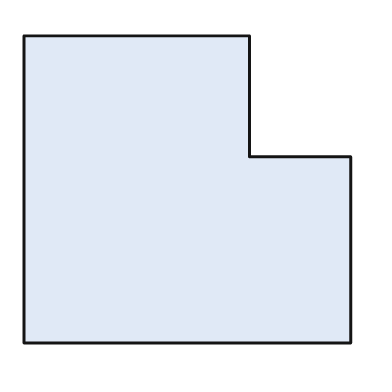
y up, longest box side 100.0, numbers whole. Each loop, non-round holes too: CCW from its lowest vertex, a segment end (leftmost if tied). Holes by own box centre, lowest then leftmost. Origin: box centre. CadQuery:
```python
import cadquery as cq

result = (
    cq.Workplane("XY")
    .moveTo(-50.0, -47.0)
    .lineTo(50.0, -47.0)
    .lineTo(50.0, 10.0)
    .lineTo(19.0, 10.0)
    .lineTo(19.0, 47.0)
    .lineTo(-50.0, 47.0)
    .close()
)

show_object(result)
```